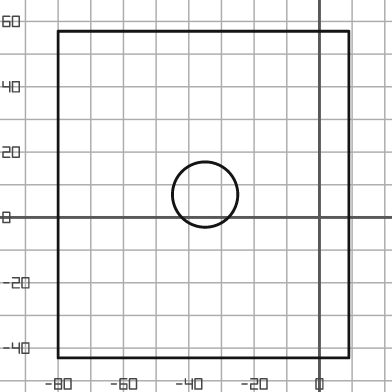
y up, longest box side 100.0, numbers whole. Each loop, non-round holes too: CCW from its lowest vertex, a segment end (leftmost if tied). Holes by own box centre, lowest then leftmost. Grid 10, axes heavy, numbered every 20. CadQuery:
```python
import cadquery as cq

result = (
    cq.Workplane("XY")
    .moveTo(-80.0, -43.0)
    .lineTo(9.0, -43.0)
    .lineTo(9.0, 57.0)
    .lineTo(-80.0, 57.0)
    .close()
    .moveTo(-35.0, 7.0)
    .circle(10.0)
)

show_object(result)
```